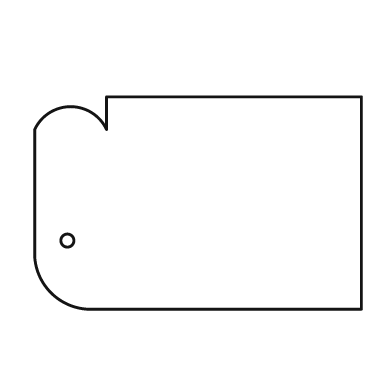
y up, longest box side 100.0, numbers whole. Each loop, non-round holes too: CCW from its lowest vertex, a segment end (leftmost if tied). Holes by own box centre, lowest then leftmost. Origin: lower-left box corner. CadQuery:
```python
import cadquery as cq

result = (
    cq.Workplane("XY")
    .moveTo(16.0, 0.0)
    .lineTo(100.0, 0.0)
    .lineTo(100.0, 65.0)
    .lineTo(22.0, 65.0)
    .lineTo(22.0, 55.0)
    .threePointArc((11.0, 62.0), (0.0, 55.0))
    .lineTo(0.0, 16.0)
    .threePointArc((5.0, 5.0), (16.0, 0.0))
    .close()
    .moveTo(10.0, 21.0)
    .circle(2.0)
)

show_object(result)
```